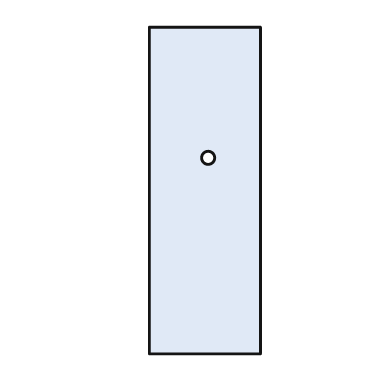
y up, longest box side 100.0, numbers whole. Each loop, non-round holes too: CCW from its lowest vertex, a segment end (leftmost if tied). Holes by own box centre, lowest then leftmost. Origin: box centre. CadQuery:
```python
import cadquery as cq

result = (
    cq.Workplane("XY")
    .moveTo(-17.0, -50.0)
    .lineTo(17.0, -50.0)
    .lineTo(17.0, 50.0)
    .lineTo(-17.0, 50.0)
    .close()
    .moveTo(1.0, 10.0)
    .circle(2.0)
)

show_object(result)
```